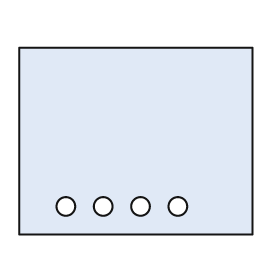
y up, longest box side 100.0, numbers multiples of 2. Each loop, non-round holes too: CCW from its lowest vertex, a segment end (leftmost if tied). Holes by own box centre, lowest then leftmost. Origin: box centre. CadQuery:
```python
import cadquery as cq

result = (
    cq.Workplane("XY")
    .moveTo(-50.0, -40.0)
    .lineTo(50.0, -40.0)
    .lineTo(50.0, 40.0)
    .lineTo(-50.0, 40.0)
    .close()
    .moveTo(-30.0, -28.0)
    .circle(4.0)
    .moveTo(-14.0, -28.0)
    .circle(4.0)
    .moveTo(2.0, -28.0)
    .circle(4.0)
    .moveTo(18.0, -28.0)
    .circle(4.0)
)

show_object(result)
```